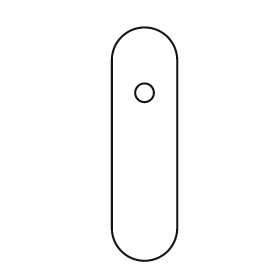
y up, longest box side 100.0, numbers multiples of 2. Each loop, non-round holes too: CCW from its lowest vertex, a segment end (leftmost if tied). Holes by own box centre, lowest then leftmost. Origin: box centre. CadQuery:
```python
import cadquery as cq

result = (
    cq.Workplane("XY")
    .moveTo(-14.0, -36.0)
    .threePointArc((0.0, -50.0), (14.0, -36.0))
    .lineTo(14.0, 36.0)
    .threePointArc((0.0, 50.0), (-14.0, 36.0))
    .close()
    .moveTo(0.0, 22.0)
    .circle(4.0)
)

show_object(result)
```